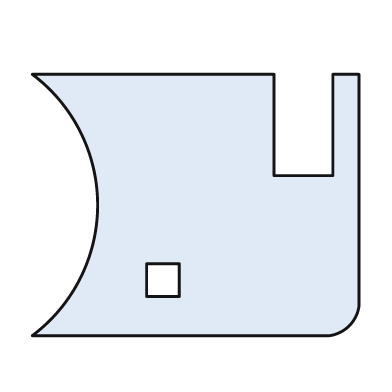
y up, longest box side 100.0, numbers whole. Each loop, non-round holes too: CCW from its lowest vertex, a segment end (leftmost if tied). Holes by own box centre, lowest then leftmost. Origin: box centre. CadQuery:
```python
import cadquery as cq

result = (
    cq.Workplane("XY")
    .moveTo(-50.0, -40.0)
    .lineTo(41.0, -40.0)
    .threePointArc((47.0, -37.0), (50.0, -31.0))
    .lineTo(50.0, 40.0)
    .lineTo(42.0, 40.0)
    .lineTo(42.0, 9.0)
    .lineTo(24.0, 9.0)
    .lineTo(24.0, 40.0)
    .lineTo(-50.0, 40.0)
    .threePointArc((-30.0, 0.0), (-50.0, -40.0))
    .close()
    .moveTo(-15.0, -28.0)
    .lineTo(-5.0, -28.0)
    .lineTo(-5.0, -18.0)
    .lineTo(-15.0, -18.0)
    .close()
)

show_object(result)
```